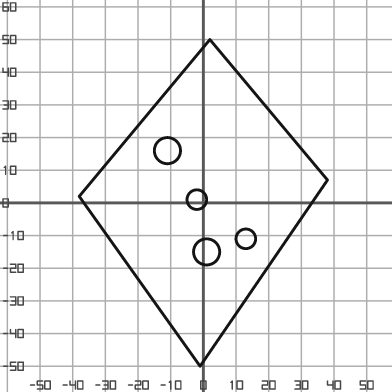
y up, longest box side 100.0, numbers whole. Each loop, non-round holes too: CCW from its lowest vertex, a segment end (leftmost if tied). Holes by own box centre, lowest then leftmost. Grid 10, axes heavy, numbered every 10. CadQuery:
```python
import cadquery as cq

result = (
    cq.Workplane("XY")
    .moveTo(-1.0, -50.0)
    .lineTo(38.0, 7.0)
    .lineTo(2.0, 50.0)
    .lineTo(-38.0, 2.0)
    .close()
    .moveTo(1.0, -15.0)
    .circle(4.0)
    .moveTo(13.0, -11.0)
    .circle(3.0)
    .moveTo(-2.0, 1.0)
    .circle(3.0)
    .moveTo(-11.0, 16.0)
    .circle(4.0)
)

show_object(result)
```